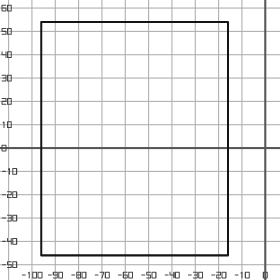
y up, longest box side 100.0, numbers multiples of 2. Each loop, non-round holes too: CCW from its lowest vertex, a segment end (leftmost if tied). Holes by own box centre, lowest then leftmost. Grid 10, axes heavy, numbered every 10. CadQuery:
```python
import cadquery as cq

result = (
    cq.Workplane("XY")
    .moveTo(-96.0, -46.0)
    .lineTo(-16.0, -46.0)
    .lineTo(-16.0, 54.0)
    .lineTo(-96.0, 54.0)
    .close()
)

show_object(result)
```